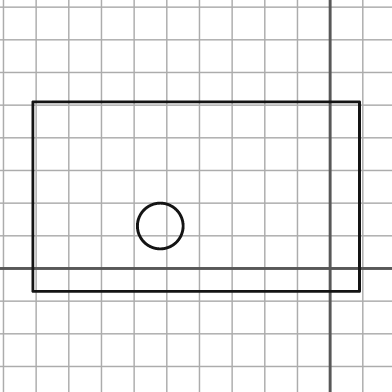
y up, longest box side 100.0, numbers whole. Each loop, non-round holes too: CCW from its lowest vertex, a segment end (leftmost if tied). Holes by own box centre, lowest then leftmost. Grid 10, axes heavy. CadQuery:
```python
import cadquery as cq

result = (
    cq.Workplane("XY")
    .moveTo(-91.0, -7.0)
    .lineTo(9.0, -7.0)
    .lineTo(9.0, 51.0)
    .lineTo(-91.0, 51.0)
    .close()
    .moveTo(-52.0, 13.0)
    .circle(7.0)
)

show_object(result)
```